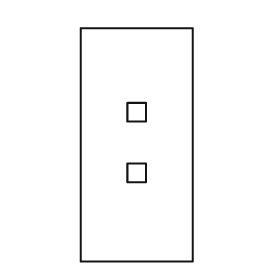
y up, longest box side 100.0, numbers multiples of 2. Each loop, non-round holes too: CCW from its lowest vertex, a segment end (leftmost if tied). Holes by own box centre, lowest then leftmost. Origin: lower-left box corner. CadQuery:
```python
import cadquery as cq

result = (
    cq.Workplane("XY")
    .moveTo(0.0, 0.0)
    .lineTo(48.0, 0.0)
    .lineTo(48.0, 100.0)
    .lineTo(0.0, 100.0)
    .close()
    .moveTo(20.0, 34.0)
    .lineTo(28.0, 34.0)
    .lineTo(28.0, 42.0)
    .lineTo(20.0, 42.0)
    .close()
    .moveTo(20.0, 60.0)
    .lineTo(28.0, 60.0)
    .lineTo(28.0, 68.0)
    .lineTo(20.0, 68.0)
    .close()
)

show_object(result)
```